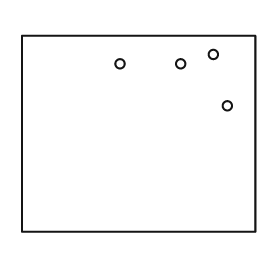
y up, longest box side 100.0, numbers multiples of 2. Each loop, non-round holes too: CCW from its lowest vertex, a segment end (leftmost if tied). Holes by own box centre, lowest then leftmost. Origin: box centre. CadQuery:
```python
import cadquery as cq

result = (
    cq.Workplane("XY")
    .moveTo(-50.0, -42.0)
    .lineTo(50.0, -42.0)
    .lineTo(50.0, 42.0)
    .lineTo(-50.0, 42.0)
    .close()
    .moveTo(38.0, 12.0)
    .circle(2.0)
    .moveTo(-8.0, 30.0)
    .circle(2.0)
    .moveTo(18.0, 30.0)
    .circle(2.0)
    .moveTo(32.0, 34.0)
    .circle(2.0)
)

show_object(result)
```